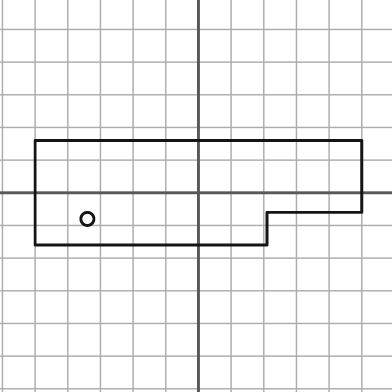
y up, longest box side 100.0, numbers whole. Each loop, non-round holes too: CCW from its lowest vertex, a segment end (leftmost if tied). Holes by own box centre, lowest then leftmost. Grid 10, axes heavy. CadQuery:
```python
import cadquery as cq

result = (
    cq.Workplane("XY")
    .moveTo(-50.0, -16.0)
    .lineTo(21.0, -16.0)
    .lineTo(21.0, -6.0)
    .lineTo(50.0, -6.0)
    .lineTo(50.0, 16.0)
    .lineTo(-50.0, 16.0)
    .close()
    .moveTo(-34.0, -8.0)
    .circle(2.0)
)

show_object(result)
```